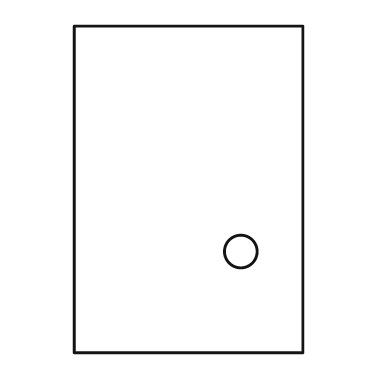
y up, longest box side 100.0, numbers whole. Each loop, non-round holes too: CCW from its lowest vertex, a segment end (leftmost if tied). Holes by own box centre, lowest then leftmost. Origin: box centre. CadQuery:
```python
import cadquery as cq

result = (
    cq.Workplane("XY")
    .moveTo(-35.0, -50.0)
    .lineTo(35.0, -50.0)
    .lineTo(35.0, 50.0)
    .lineTo(-35.0, 50.0)
    .close()
    .moveTo(16.0, -19.0)
    .circle(5.0)
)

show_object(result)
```